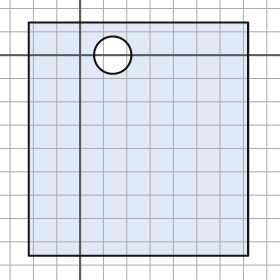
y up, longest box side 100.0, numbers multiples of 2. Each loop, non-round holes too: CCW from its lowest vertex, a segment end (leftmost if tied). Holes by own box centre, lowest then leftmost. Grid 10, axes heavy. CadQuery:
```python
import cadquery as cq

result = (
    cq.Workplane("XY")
    .moveTo(-22.0, -86.0)
    .lineTo(72.0, -86.0)
    .lineTo(72.0, 14.0)
    .lineTo(-22.0, 14.0)
    .close()
    .moveTo(14.0, 0.0)
    .circle(8.0)
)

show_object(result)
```